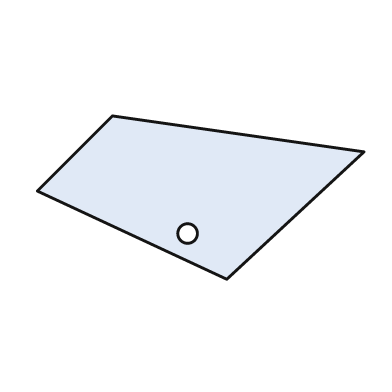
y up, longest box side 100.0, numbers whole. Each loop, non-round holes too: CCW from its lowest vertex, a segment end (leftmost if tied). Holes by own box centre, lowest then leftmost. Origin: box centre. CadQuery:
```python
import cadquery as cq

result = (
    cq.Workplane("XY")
    .moveTo(8.0, -25.0)
    .lineTo(50.0, 14.0)
    .lineTo(-27.0, 25.0)
    .lineTo(-50.0, 2.0)
    .close()
    .moveTo(-4.0, -11.0)
    .circle(3.0)
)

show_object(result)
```